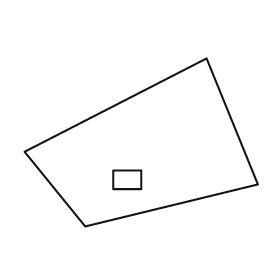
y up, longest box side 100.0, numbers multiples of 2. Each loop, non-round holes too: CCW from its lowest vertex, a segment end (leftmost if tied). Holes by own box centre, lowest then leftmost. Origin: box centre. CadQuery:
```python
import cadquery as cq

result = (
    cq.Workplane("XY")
    .moveTo(-24.0, -36.0)
    .lineTo(50.0, -18.0)
    .lineTo(28.0, 36.0)
    .lineTo(-50.0, -4.0)
    .close()
    .moveTo(-12.0, -20.0)
    .lineTo(0.0, -20.0)
    .lineTo(0.0, -12.0)
    .lineTo(-12.0, -12.0)
    .close()
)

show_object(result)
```